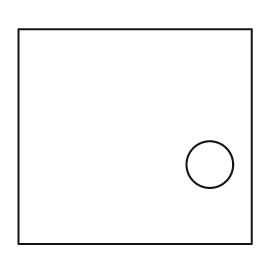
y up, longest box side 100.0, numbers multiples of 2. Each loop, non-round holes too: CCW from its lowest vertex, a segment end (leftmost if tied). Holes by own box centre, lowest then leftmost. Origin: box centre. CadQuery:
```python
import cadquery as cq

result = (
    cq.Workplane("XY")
    .moveTo(-50.0, -46.0)
    .lineTo(50.0, -46.0)
    .lineTo(50.0, 46.0)
    .lineTo(-50.0, 46.0)
    .close()
    .moveTo(32.0, -12.0)
    .circle(10.0)
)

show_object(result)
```